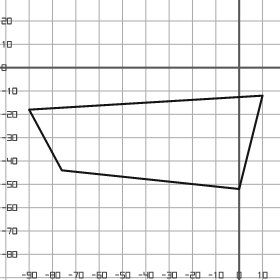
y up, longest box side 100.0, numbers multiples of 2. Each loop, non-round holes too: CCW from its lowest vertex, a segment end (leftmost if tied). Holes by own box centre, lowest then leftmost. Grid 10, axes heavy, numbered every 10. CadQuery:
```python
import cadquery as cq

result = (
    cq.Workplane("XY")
    .moveTo(0.0, -52.0)
    .lineTo(10.0, -12.0)
    .lineTo(-90.0, -18.0)
    .lineTo(-76.0, -44.0)
    .close()
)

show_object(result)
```